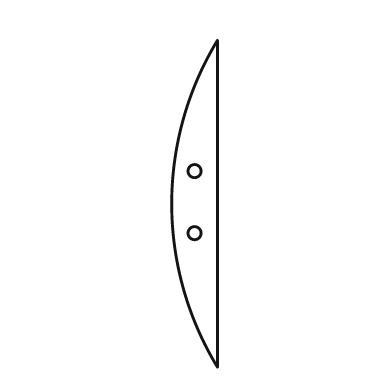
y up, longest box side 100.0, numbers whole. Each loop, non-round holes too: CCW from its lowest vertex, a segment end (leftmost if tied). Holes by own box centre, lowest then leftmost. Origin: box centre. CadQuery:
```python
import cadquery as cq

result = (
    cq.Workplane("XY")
    .moveTo(7.0, -50.0)
    .lineTo(7.0, 50.0)
    .threePointArc((-7.0, 0.0), (7.0, -50.0))
    .close()
    .moveTo(0.0, -9.0)
    .circle(2.0)
    .moveTo(0.0, 10.0)
    .circle(2.0)
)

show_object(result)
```